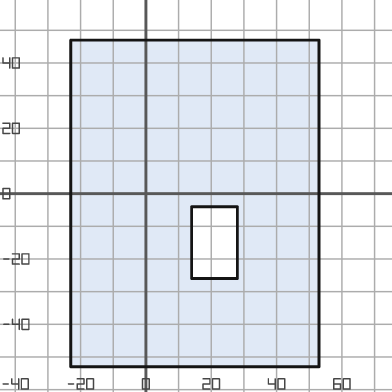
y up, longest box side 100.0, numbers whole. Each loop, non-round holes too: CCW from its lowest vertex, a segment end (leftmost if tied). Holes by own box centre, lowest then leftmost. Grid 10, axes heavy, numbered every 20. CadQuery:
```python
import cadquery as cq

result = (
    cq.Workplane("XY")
    .moveTo(-23.0, -53.0)
    .lineTo(53.0, -53.0)
    .lineTo(53.0, 47.0)
    .lineTo(-23.0, 47.0)
    .close()
    .moveTo(14.0, -26.0)
    .lineTo(28.0, -26.0)
    .lineTo(28.0, -4.0)
    .lineTo(14.0, -4.0)
    .close()
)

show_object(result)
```